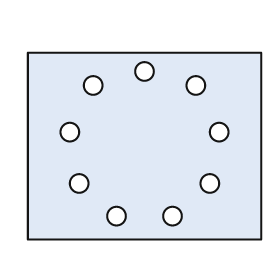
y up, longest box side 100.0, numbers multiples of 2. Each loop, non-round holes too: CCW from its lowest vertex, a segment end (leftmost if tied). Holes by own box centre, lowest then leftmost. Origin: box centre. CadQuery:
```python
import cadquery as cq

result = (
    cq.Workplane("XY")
    .moveTo(-50.0, -40.0)
    .lineTo(50.0, -40.0)
    .lineTo(50.0, 40.0)
    .lineTo(-50.0, 40.0)
    .close()
    .moveTo(-12.0, -30.0)
    .circle(4.0)
    .moveTo(12.0, -30.0)
    .circle(4.0)
    .moveTo(-28.0, -16.0)
    .circle(4.0)
    .moveTo(28.0, -16.0)
    .circle(4.0)
    .moveTo(-32.0, 6.0)
    .circle(4.0)
    .moveTo(32.0, 6.0)
    .circle(4.0)
    .moveTo(-22.0, 26.0)
    .circle(4.0)
    .moveTo(22.0, 26.0)
    .circle(4.0)
    .moveTo(0.0, 32.0)
    .circle(4.0)
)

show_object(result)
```